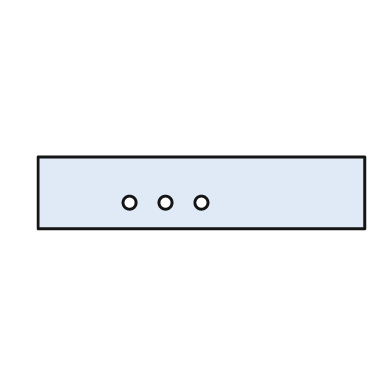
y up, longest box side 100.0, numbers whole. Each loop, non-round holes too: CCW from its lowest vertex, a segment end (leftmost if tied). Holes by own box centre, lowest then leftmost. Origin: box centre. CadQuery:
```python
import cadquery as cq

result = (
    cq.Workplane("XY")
    .moveTo(-50.0, -11.0)
    .lineTo(50.0, -11.0)
    .lineTo(50.0, 11.0)
    .lineTo(-50.0, 11.0)
    .close()
    .moveTo(-22.0, -3.0)
    .circle(2.0)
    .moveTo(-11.0, -3.0)
    .circle(2.0)
    .moveTo(0.0, -3.0)
    .circle(2.0)
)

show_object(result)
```